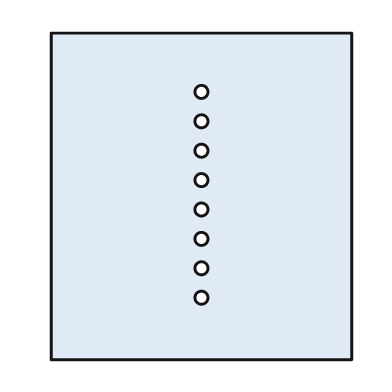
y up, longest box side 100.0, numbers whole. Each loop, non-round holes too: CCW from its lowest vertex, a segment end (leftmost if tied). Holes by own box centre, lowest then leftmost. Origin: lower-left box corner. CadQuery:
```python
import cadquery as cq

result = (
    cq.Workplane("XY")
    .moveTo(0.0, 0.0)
    .lineTo(92.0, 0.0)
    .lineTo(92.0, 100.0)
    .lineTo(0.0, 100.0)
    .close()
    .moveTo(46.0, 19.0)
    .circle(2.0)
    .moveTo(46.0, 28.0)
    .circle(2.0)
    .moveTo(46.0, 37.0)
    .circle(2.0)
    .moveTo(46.0, 46.0)
    .circle(2.0)
    .moveTo(46.0, 55.0)
    .circle(2.0)
    .moveTo(46.0, 64.0)
    .circle(2.0)
    .moveTo(46.0, 73.0)
    .circle(2.0)
    .moveTo(46.0, 82.0)
    .circle(2.0)
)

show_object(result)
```